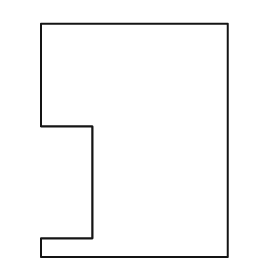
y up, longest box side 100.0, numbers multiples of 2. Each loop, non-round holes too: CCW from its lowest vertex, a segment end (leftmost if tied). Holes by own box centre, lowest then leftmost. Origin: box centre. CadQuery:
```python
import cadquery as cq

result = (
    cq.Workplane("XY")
    .moveTo(-40.0, -50.0)
    .lineTo(40.0, -50.0)
    .lineTo(40.0, 50.0)
    .lineTo(-40.0, 50.0)
    .lineTo(-40.0, 6.0)
    .lineTo(-18.0, 6.0)
    .lineTo(-18.0, -42.0)
    .lineTo(-40.0, -42.0)
    .close()
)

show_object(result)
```